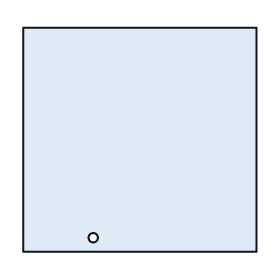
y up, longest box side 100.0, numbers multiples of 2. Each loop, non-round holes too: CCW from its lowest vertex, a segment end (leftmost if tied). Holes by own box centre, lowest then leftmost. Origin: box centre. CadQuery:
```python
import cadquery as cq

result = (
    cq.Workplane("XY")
    .moveTo(-50.0, -48.0)
    .lineTo(50.0, -48.0)
    .lineTo(50.0, 48.0)
    .lineTo(-50.0, 48.0)
    .close()
    .moveTo(-20.0, -42.0)
    .circle(2.0)
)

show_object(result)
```